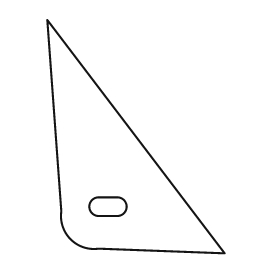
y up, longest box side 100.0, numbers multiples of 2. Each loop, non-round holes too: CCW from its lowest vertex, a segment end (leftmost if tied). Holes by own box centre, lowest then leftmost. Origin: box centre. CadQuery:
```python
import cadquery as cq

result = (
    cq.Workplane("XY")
    .moveTo(38.0, -50.0)
    .lineTo(-38.0, 50.0)
    .lineTo(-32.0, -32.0)
    .threePointArc((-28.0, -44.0), (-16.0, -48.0))
    .close()
    .moveTo(-16.0, -34.0)
    .lineTo(-8.0, -34.0)
    .threePointArc((-4.0, -30.0), (-8.0, -26.0))
    .lineTo(-16.0, -26.0)
    .threePointArc((-20.0, -30.0), (-16.0, -34.0))
    .close()
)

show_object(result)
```